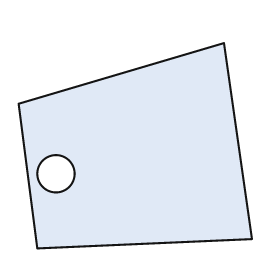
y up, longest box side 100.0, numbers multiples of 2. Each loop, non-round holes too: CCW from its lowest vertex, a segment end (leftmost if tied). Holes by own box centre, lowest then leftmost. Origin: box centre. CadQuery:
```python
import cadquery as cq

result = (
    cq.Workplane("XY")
    .moveTo(-42.0, -44.0)
    .lineTo(50.0, -40.0)
    .lineTo(38.0, 44.0)
    .lineTo(-50.0, 18.0)
    .close()
    .moveTo(-34.0, -12.0)
    .circle(8.0)
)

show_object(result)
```